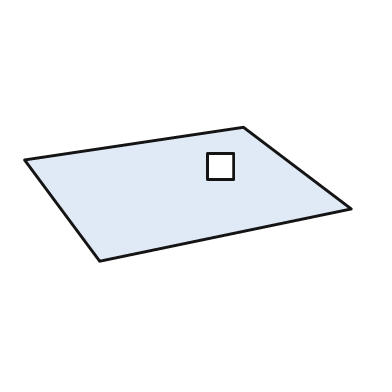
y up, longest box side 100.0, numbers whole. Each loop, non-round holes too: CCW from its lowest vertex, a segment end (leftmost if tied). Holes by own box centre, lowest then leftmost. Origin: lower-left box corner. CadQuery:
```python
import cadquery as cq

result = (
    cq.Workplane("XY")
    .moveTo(23.0, 0.0)
    .lineTo(100.0, 16.0)
    .lineTo(67.0, 41.0)
    .lineTo(0.0, 31.0)
    .close()
    .moveTo(56.0, 25.0)
    .lineTo(64.0, 25.0)
    .lineTo(64.0, 33.0)
    .lineTo(56.0, 33.0)
    .close()
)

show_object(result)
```